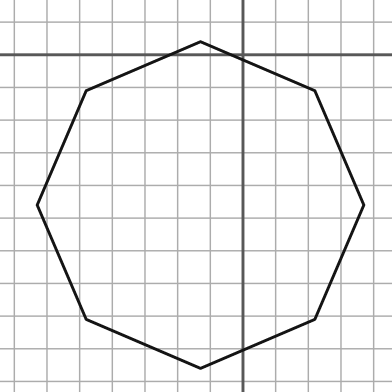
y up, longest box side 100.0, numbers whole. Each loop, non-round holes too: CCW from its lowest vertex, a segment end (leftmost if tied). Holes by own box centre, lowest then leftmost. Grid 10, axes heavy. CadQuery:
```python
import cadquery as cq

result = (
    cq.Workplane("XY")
    .moveTo(-13.0, -96.0)
    .lineTo(22.0, -81.0)
    .lineTo(37.0, -46.0)
    .lineTo(22.0, -11.0)
    .lineTo(-13.0, 4.0)
    .lineTo(-48.0, -11.0)
    .lineTo(-63.0, -46.0)
    .lineTo(-48.0, -81.0)
    .close()
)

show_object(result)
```